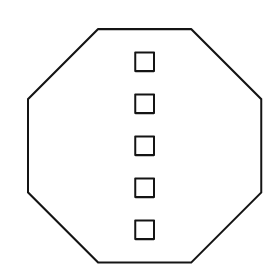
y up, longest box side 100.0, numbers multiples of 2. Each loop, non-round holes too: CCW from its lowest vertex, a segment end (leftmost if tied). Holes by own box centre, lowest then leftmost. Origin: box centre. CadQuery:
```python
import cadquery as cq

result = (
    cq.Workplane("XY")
    .moveTo(-20.0, -50.0)
    .lineTo(20.0, -50.0)
    .lineTo(50.0, -20.0)
    .lineTo(50.0, 20.0)
    .lineTo(20.0, 50.0)
    .lineTo(-20.0, 50.0)
    .lineTo(-50.0, 20.0)
    .lineTo(-50.0, -20.0)
    .close()
    .moveTo(-4.0, -40.0)
    .lineTo(4.0, -40.0)
    .lineTo(4.0, -32.0)
    .lineTo(-4.0, -32.0)
    .close()
    .moveTo(-4.0, -22.0)
    .lineTo(4.0, -22.0)
    .lineTo(4.0, -14.0)
    .lineTo(-4.0, -14.0)
    .close()
    .moveTo(-4.0, -4.0)
    .lineTo(4.0, -4.0)
    .lineTo(4.0, 4.0)
    .lineTo(-4.0, 4.0)
    .close()
    .moveTo(-4.0, 14.0)
    .lineTo(4.0, 14.0)
    .lineTo(4.0, 22.0)
    .lineTo(-4.0, 22.0)
    .close()
    .moveTo(-4.0, 32.0)
    .lineTo(4.0, 32.0)
    .lineTo(4.0, 40.0)
    .lineTo(-4.0, 40.0)
    .close()
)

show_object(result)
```